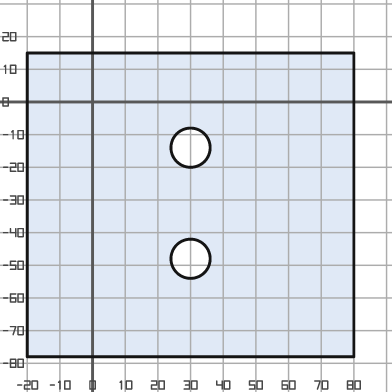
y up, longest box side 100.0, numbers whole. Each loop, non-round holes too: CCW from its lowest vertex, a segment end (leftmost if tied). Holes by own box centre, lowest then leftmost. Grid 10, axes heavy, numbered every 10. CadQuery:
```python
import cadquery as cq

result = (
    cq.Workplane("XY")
    .moveTo(-20.0, -78.0)
    .lineTo(80.0, -78.0)
    .lineTo(80.0, 15.0)
    .lineTo(-20.0, 15.0)
    .close()
    .moveTo(30.0, -48.0)
    .circle(6.0)
    .moveTo(30.0, -14.0)
    .circle(6.0)
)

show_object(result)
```